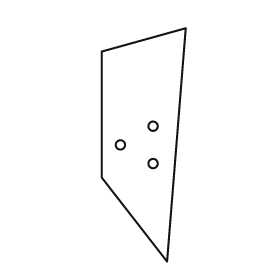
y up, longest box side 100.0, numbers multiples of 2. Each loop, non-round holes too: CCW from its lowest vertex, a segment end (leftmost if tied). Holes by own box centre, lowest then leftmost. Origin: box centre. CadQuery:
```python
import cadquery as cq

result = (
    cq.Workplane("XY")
    .moveTo(10.0, -50.0)
    .lineTo(18.0, 50.0)
    .lineTo(-18.0, 40.0)
    .lineTo(-18.0, -14.0)
    .close()
    .moveTo(4.0, -8.0)
    .circle(2.0)
    .moveTo(-10.0, 0.0)
    .circle(2.0)
    .moveTo(4.0, 8.0)
    .circle(2.0)
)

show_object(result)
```